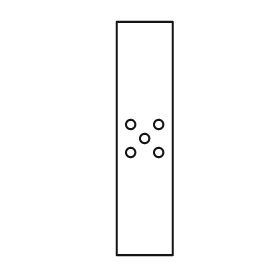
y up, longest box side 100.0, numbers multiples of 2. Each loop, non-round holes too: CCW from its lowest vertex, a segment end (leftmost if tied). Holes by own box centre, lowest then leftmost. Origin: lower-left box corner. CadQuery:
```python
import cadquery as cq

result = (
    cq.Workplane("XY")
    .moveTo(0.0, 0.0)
    .lineTo(24.0, 0.0)
    .lineTo(24.0, 100.0)
    .lineTo(0.0, 100.0)
    .close()
    .moveTo(6.0, 44.0)
    .circle(2.0)
    .moveTo(18.0, 44.0)
    .circle(2.0)
    .moveTo(12.0, 50.0)
    .circle(2.0)
    .moveTo(6.0, 56.0)
    .circle(2.0)
    .moveTo(18.0, 56.0)
    .circle(2.0)
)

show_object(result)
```